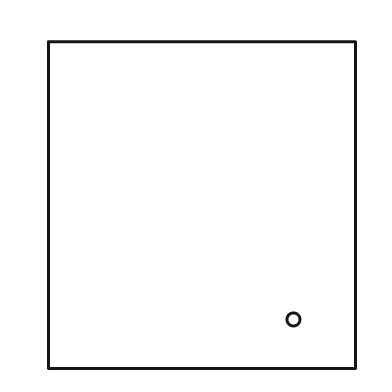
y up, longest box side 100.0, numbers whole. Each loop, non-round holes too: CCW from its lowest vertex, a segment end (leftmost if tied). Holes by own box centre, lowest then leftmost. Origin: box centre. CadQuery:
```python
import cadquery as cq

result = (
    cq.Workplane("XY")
    .moveTo(-47.0, -50.0)
    .lineTo(47.0, -50.0)
    .lineTo(47.0, 50.0)
    .lineTo(-47.0, 50.0)
    .close()
    .moveTo(28.0, -35.0)
    .circle(2.0)
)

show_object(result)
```